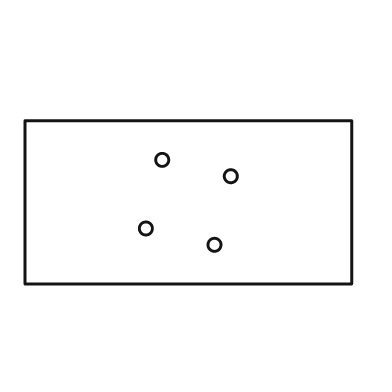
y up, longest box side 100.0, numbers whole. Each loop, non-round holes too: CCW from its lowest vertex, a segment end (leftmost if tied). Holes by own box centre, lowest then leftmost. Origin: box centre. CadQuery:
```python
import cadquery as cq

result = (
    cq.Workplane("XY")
    .moveTo(-50.0, -25.0)
    .lineTo(50.0, -25.0)
    .lineTo(50.0, 25.0)
    .lineTo(-50.0, 25.0)
    .close()
    .moveTo(8.0, -13.0)
    .circle(2.0)
    .moveTo(-13.0, -8.0)
    .circle(2.0)
    .moveTo(13.0, 8.0)
    .circle(2.0)
    .moveTo(-8.0, 13.0)
    .circle(2.0)
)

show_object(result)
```